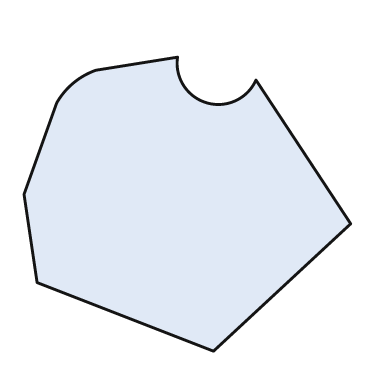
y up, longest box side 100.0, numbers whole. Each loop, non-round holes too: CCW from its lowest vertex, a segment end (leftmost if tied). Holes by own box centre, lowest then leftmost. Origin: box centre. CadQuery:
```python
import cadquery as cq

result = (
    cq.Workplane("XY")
    .moveTo(8.0, -45.0)
    .lineTo(50.0, -6.0)
    .lineTo(21.0, 38.0)
    .threePointArc((6.0, 31.0), (-3.0, 45.0))
    .lineTo(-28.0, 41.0)
    .threePointArc((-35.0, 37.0), (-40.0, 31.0))
    .lineTo(-50.0, 3.0)
    .lineTo(-46.0, -24.0)
    .close()
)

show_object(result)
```